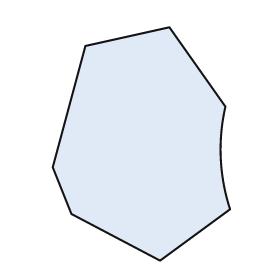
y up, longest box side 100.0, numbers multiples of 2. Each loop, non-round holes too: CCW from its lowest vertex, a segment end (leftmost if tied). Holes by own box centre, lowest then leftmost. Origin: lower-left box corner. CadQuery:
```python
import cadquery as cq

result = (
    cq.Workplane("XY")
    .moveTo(46.0, 0.0)
    .lineTo(76.0, 22.0)
    .threePointArc((72.0, 44.0), (74.0, 66.0))
    .lineTo(50.0, 100.0)
    .lineTo(14.0, 92.0)
    .lineTo(0.0, 40.0)
    .lineTo(8.0, 20.0)
    .close()
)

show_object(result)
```